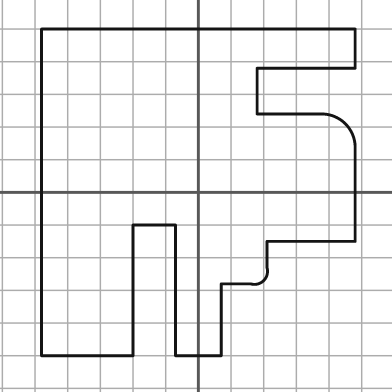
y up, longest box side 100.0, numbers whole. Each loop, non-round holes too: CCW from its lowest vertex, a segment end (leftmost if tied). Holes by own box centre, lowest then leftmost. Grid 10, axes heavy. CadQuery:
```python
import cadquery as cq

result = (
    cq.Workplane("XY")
    .moveTo(-48.0, -50.0)
    .lineTo(-20.0, -50.0)
    .lineTo(-20.0, -10.0)
    .lineTo(-7.0, -10.0)
    .lineTo(-7.0, -50.0)
    .lineTo(7.0, -50.0)
    .lineTo(7.0, -28.0)
    .lineTo(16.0, -28.0)
    .threePointArc((20.0, -27.0), (21.0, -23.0))
    .lineTo(21.0, -15.0)
    .lineTo(48.0, -15.0)
    .lineTo(48.0, 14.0)
    .threePointArc((45.0, 21.0), (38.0, 24.0))
    .lineTo(18.0, 24.0)
    .lineTo(18.0, 38.0)
    .lineTo(48.0, 38.0)
    .lineTo(48.0, 50.0)
    .lineTo(-48.0, 50.0)
    .close()
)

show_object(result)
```